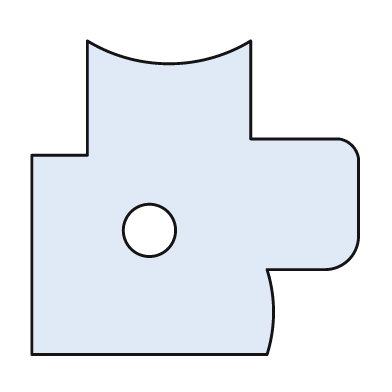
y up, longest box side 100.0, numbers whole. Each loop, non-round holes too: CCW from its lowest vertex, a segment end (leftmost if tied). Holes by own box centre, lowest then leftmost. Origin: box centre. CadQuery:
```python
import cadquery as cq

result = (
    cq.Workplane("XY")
    .moveTo(-50.0, -48.0)
    .lineTo(22.0, -48.0)
    .threePointArc((24.0, -35.0), (22.0, -22.0))
    .lineTo(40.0, -22.0)
    .threePointArc((47.0, -19.0), (50.0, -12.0))
    .lineTo(50.0, 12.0)
    .threePointArc((48.0, 16.0), (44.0, 18.0))
    .lineTo(17.0, 18.0)
    .lineTo(17.0, 48.0)
    .threePointArc((-8.0, 41.0), (-33.0, 48.0))
    .lineTo(-33.0, 13.0)
    .lineTo(-50.0, 13.0)
    .close()
    .moveTo(-14.0, -10.0)
    .circle(8.0)
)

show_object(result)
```